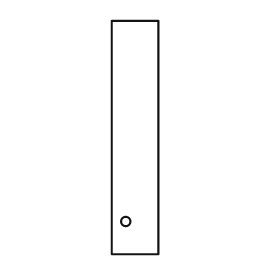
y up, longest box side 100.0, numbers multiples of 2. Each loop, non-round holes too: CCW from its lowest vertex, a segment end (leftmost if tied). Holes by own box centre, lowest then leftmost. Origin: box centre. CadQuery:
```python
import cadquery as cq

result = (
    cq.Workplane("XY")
    .moveTo(-10.0, -50.0)
    .lineTo(10.0, -50.0)
    .lineTo(10.0, 50.0)
    .lineTo(-10.0, 50.0)
    .close()
    .moveTo(-4.0, -36.0)
    .circle(2.0)
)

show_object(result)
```